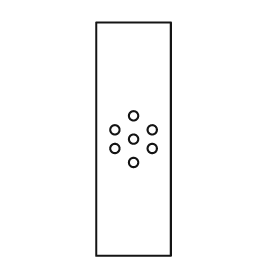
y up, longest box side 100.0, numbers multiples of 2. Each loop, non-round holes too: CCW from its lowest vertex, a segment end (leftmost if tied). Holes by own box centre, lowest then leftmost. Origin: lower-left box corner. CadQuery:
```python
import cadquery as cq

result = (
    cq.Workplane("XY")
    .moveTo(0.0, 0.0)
    .lineTo(32.0, 0.0)
    .lineTo(32.0, 100.0)
    .lineTo(0.0, 100.0)
    .close()
    .moveTo(16.0, 40.0)
    .circle(2.0)
    .moveTo(8.0, 46.0)
    .circle(2.0)
    .moveTo(24.0, 46.0)
    .circle(2.0)
    .moveTo(16.0, 50.0)
    .circle(2.0)
    .moveTo(8.0, 54.0)
    .circle(2.0)
    .moveTo(24.0, 54.0)
    .circle(2.0)
    .moveTo(16.0, 60.0)
    .circle(2.0)
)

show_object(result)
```